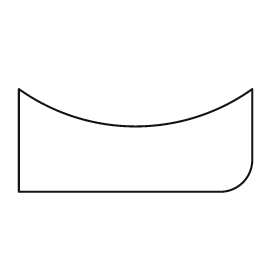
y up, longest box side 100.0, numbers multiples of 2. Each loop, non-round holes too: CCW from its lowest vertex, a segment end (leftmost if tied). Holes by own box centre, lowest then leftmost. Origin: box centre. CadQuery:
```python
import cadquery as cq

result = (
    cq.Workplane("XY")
    .moveTo(-50.0, -22.0)
    .lineTo(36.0, -22.0)
    .threePointArc((46.0, -18.0), (50.0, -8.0))
    .lineTo(50.0, 22.0)
    .threePointArc((0.0, 6.0), (-50.0, 22.0))
    .close()
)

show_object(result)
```